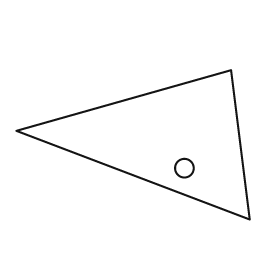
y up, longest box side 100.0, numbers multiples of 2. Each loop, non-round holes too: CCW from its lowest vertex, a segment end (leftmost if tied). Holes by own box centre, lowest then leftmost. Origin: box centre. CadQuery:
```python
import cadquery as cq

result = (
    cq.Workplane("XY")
    .moveTo(50.0, -32.0)
    .lineTo(42.0, 32.0)
    .lineTo(-50.0, 6.0)
    .close()
    .moveTo(22.0, -10.0)
    .circle(4.0)
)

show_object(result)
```